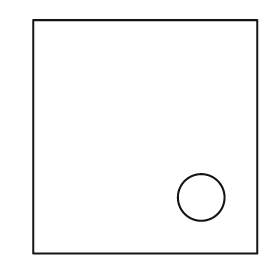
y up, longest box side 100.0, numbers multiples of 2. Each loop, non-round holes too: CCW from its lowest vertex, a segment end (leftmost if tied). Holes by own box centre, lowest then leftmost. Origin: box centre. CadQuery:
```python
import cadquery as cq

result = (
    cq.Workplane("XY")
    .moveTo(-48.0, -50.0)
    .lineTo(48.0, -50.0)
    .lineTo(48.0, 50.0)
    .lineTo(-48.0, 50.0)
    .close()
    .moveTo(24.0, -26.0)
    .circle(10.0)
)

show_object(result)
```